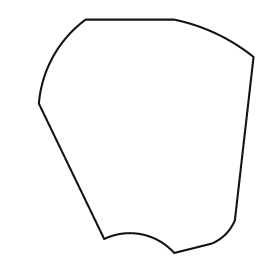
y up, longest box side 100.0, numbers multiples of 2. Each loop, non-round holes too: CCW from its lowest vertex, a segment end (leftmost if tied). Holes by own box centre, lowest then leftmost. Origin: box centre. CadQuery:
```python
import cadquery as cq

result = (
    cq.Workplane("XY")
    .moveTo(12.0, -50.0)
    .lineTo(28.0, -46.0)
    .threePointArc((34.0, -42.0), (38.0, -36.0))
    .lineTo(46.0, 34.0)
    .threePointArc((30.0, 44.0), (12.0, 50.0))
    .lineTo(-26.0, 50.0)
    .threePointArc((-40.0, 34.0), (-46.0, 14.0))
    .lineTo(-18.0, -44.0)
    .threePointArc((-2.0, -42.0), (12.0, -50.0))
    .close()
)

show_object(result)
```